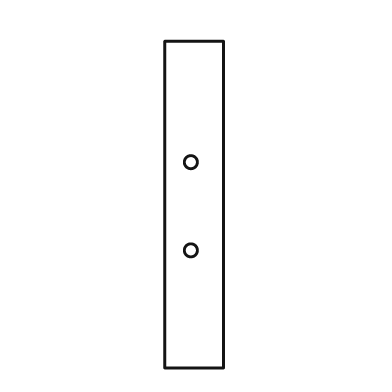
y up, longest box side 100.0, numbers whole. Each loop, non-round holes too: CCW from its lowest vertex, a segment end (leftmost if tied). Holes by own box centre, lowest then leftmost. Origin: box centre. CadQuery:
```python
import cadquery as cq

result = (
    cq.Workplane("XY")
    .moveTo(-9.0, -50.0)
    .lineTo(9.0, -50.0)
    .lineTo(9.0, 50.0)
    .lineTo(-9.0, 50.0)
    .close()
    .moveTo(-1.0, -14.0)
    .circle(2.0)
    .moveTo(-1.0, 13.0)
    .circle(2.0)
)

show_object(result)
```